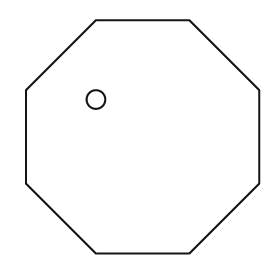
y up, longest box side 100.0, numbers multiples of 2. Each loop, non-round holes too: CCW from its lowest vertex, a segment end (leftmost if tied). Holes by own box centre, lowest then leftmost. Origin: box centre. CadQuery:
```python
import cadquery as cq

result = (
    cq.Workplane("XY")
    .moveTo(-20.0, -50.0)
    .lineTo(20.0, -50.0)
    .lineTo(50.0, -20.0)
    .lineTo(50.0, 20.0)
    .lineTo(20.0, 50.0)
    .lineTo(-20.0, 50.0)
    .lineTo(-50.0, 20.0)
    .lineTo(-50.0, -20.0)
    .close()
    .moveTo(-20.0, 16.0)
    .circle(4.0)
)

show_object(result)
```